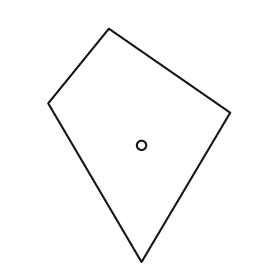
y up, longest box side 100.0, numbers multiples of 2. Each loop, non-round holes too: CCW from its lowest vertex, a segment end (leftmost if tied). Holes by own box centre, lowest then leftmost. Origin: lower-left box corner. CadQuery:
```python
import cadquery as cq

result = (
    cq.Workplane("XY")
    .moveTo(40.0, 0.0)
    .lineTo(78.0, 64.0)
    .lineTo(26.0, 100.0)
    .lineTo(0.0, 68.0)
    .close()
    .moveTo(40.0, 50.0)
    .circle(2.0)
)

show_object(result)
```